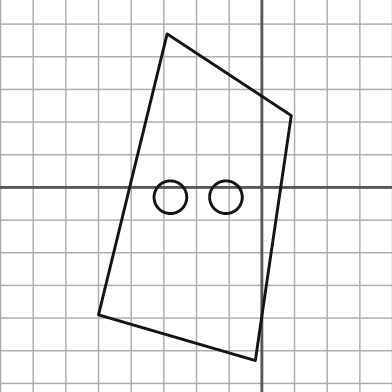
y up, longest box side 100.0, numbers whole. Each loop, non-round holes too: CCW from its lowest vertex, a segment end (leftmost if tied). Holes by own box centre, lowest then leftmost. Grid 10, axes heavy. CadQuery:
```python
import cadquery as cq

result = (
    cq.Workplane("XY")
    .moveTo(-2.0, -53.0)
    .lineTo(9.0, 22.0)
    .lineTo(-29.0, 47.0)
    .lineTo(-50.0, -39.0)
    .close()
    .moveTo(-28.0, -3.0)
    .circle(5.0)
    .moveTo(-11.0, -3.0)
    .circle(5.0)
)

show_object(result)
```